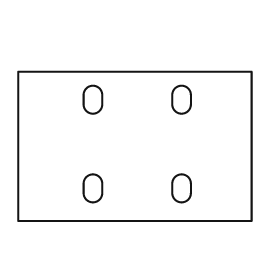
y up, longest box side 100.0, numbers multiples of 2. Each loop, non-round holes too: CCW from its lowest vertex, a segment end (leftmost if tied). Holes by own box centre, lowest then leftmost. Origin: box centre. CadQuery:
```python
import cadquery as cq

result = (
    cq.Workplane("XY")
    .moveTo(-50.0, -32.0)
    .lineTo(50.0, -32.0)
    .lineTo(50.0, 32.0)
    .lineTo(-50.0, 32.0)
    .close()
    .moveTo(-22.0, -20.0)
    .threePointArc((-18.0, -24.0), (-14.0, -20.0))
    .lineTo(-14.0, -16.0)
    .threePointArc((-18.0, -12.0), (-22.0, -16.0))
    .close()
    .moveTo(16.0, -20.0)
    .threePointArc((20.0, -24.0), (24.0, -20.0))
    .lineTo(24.0, -16.0)
    .threePointArc((20.0, -12.0), (16.0, -16.0))
    .close()
    .moveTo(-22.0, 18.0)
    .threePointArc((-18.0, 14.0), (-14.0, 18.0))
    .lineTo(-14.0, 22.0)
    .threePointArc((-18.0, 26.0), (-22.0, 22.0))
    .close()
    .moveTo(16.0, 18.0)
    .threePointArc((20.0, 14.0), (24.0, 18.0))
    .lineTo(24.0, 22.0)
    .threePointArc((20.0, 26.0), (16.0, 22.0))
    .close()
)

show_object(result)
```